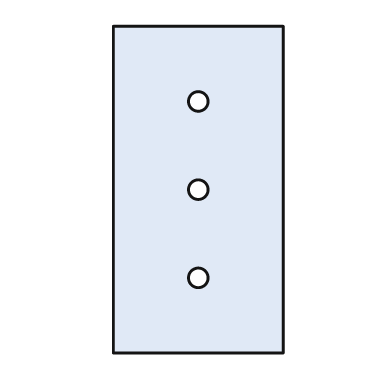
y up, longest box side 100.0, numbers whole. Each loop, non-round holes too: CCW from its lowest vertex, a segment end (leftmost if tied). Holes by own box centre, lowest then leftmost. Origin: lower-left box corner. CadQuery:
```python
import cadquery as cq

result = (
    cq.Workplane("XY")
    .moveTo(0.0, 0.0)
    .lineTo(52.0, 0.0)
    .lineTo(52.0, 100.0)
    .lineTo(0.0, 100.0)
    .close()
    .moveTo(26.0, 23.0)
    .circle(3.0)
    .moveTo(26.0, 50.0)
    .circle(3.0)
    .moveTo(26.0, 77.0)
    .circle(3.0)
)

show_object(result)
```